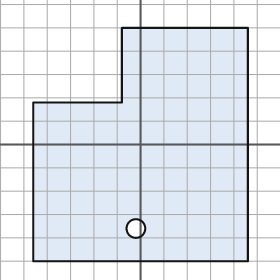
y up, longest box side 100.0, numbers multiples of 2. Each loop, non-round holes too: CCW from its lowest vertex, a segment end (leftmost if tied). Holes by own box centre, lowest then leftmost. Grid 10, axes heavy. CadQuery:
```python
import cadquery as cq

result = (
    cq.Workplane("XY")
    .moveTo(-46.0, -50.0)
    .lineTo(46.0, -50.0)
    .lineTo(46.0, 50.0)
    .lineTo(-8.0, 50.0)
    .lineTo(-8.0, 18.0)
    .lineTo(-46.0, 18.0)
    .close()
    .moveTo(-2.0, -36.0)
    .circle(4.0)
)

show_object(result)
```